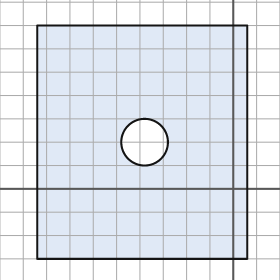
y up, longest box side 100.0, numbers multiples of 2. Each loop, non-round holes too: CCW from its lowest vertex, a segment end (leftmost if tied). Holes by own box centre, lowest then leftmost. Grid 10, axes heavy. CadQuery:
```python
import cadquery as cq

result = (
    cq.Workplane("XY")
    .moveTo(-84.0, -30.0)
    .lineTo(6.0, -30.0)
    .lineTo(6.0, 70.0)
    .lineTo(-84.0, 70.0)
    .close()
    .moveTo(-38.0, 20.0)
    .circle(10.0)
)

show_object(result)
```